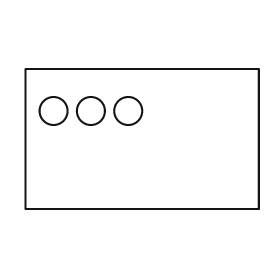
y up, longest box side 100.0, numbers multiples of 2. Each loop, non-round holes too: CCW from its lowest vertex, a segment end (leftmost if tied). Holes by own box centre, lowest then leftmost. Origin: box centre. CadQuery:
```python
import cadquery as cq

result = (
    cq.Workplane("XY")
    .moveTo(-50.0, -30.0)
    .lineTo(50.0, -30.0)
    .lineTo(50.0, 30.0)
    .lineTo(-50.0, 30.0)
    .close()
    .moveTo(-38.0, 12.0)
    .circle(6.0)
    .moveTo(-22.0, 12.0)
    .circle(6.0)
    .moveTo(-6.0, 12.0)
    .circle(6.0)
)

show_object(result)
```